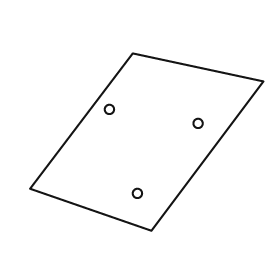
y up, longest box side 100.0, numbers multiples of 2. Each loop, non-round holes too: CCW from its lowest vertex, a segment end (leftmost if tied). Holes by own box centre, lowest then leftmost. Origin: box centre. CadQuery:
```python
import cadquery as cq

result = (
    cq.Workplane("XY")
    .moveTo(2.0, -38.0)
    .lineTo(50.0, 26.0)
    .lineTo(-6.0, 38.0)
    .lineTo(-50.0, -20.0)
    .close()
    .moveTo(-4.0, -22.0)
    .circle(2.0)
    .moveTo(22.0, 8.0)
    .circle(2.0)
    .moveTo(-16.0, 14.0)
    .circle(2.0)
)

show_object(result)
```